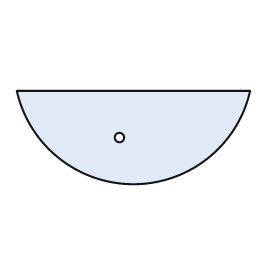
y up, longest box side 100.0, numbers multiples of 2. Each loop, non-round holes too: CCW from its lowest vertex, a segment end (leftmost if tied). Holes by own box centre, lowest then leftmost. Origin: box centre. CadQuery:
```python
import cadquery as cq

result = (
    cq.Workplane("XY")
    .moveTo(-50.0, 20.0)
    .threePointArc((0.0, -20.0), (50.0, 20.0))
    .close()
    .moveTo(-6.0, 0.0)
    .circle(2.0)
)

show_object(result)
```